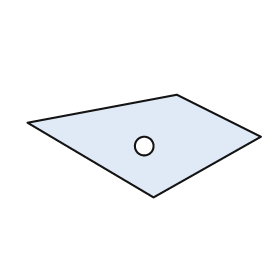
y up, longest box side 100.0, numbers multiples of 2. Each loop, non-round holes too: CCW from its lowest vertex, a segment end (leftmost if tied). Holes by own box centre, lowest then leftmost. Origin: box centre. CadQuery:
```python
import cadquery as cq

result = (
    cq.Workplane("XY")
    .moveTo(4.0, -22.0)
    .lineTo(50.0, 4.0)
    .lineTo(14.0, 22.0)
    .lineTo(-50.0, 10.0)
    .close()
    .moveTo(0.0, 0.0)
    .circle(4.0)
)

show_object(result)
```